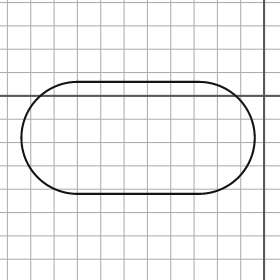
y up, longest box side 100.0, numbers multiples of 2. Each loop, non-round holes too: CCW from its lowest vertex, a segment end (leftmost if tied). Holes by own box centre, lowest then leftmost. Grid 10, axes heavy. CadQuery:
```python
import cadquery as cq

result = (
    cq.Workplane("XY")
    .moveTo(-80.0, -42.0)
    .lineTo(-28.0, -42.0)
    .threePointArc((-4.0, -18.0), (-28.0, 6.0))
    .lineTo(-80.0, 6.0)
    .threePointArc((-104.0, -18.0), (-80.0, -42.0))
    .close()
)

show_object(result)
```